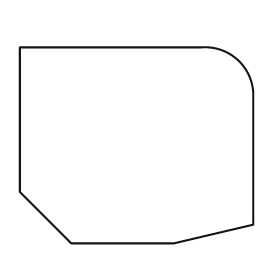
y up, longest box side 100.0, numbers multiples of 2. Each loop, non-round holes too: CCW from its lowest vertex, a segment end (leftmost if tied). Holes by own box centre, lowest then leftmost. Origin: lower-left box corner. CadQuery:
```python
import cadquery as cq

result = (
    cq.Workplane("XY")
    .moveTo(22.0, 0.0)
    .lineTo(66.0, 0.0)
    .lineTo(100.0, 8.0)
    .lineTo(100.0, 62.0)
    .threePointArc((94.0, 78.0), (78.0, 84.0))
    .lineTo(0.0, 84.0)
    .lineTo(0.0, 22.0)
    .close()
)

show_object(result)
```